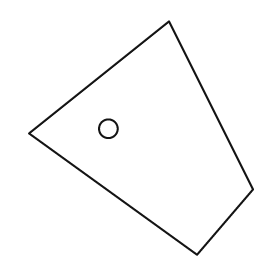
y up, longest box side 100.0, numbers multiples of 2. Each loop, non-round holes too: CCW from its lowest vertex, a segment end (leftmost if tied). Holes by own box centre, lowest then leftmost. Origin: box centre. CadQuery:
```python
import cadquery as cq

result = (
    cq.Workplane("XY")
    .moveTo(24.0, -50.0)
    .lineTo(48.0, -22.0)
    .lineTo(12.0, 50.0)
    .lineTo(-48.0, 2.0)
    .close()
    .moveTo(-14.0, 4.0)
    .circle(4.0)
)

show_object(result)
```